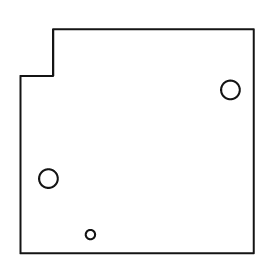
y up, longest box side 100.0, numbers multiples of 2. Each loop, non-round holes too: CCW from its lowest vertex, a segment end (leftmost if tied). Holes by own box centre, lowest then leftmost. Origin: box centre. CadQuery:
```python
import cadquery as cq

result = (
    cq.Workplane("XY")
    .moveTo(-50.0, -48.0)
    .lineTo(50.0, -48.0)
    .lineTo(50.0, 48.0)
    .lineTo(-36.0, 48.0)
    .lineTo(-36.0, 28.0)
    .lineTo(-50.0, 28.0)
    .close()
    .moveTo(-20.0, -40.0)
    .circle(2.0)
    .moveTo(-38.0, -16.0)
    .circle(4.0)
    .moveTo(40.0, 22.0)
    .circle(4.0)
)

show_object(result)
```